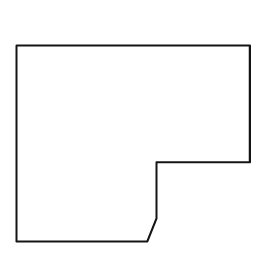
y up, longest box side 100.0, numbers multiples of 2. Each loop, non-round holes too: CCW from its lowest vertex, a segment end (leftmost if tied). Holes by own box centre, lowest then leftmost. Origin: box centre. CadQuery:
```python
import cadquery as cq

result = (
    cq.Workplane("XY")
    .moveTo(-50.0, -42.0)
    .lineTo(6.0, -42.0)
    .lineTo(10.0, -32.0)
    .lineTo(10.0, -8.0)
    .lineTo(50.0, -8.0)
    .lineTo(50.0, 42.0)
    .lineTo(-50.0, 42.0)
    .close()
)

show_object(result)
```